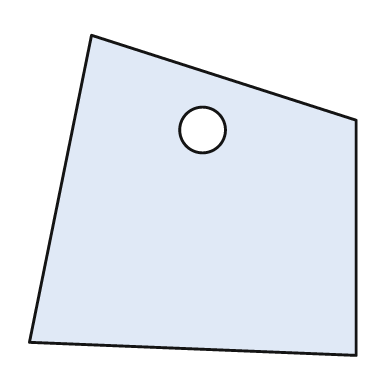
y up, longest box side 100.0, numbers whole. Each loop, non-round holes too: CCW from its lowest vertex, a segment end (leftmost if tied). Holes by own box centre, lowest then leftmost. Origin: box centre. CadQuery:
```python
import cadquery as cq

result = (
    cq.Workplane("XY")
    .moveTo(50.0, -49.0)
    .lineTo(50.0, 23.0)
    .lineTo(-31.0, 49.0)
    .lineTo(-50.0, -45.0)
    .close()
    .moveTo(3.0, 20.0)
    .circle(7.0)
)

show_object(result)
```